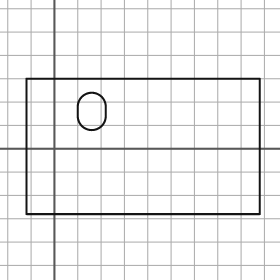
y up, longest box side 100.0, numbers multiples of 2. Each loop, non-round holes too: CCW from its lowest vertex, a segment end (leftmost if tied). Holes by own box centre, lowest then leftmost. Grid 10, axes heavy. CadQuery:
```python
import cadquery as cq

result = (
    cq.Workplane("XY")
    .moveTo(-12.0, -28.0)
    .lineTo(88.0, -28.0)
    .lineTo(88.0, 30.0)
    .lineTo(-12.0, 30.0)
    .close()
    .moveTo(10.0, 14.0)
    .threePointArc((16.0, 8.0), (22.0, 14.0))
    .lineTo(22.0, 18.0)
    .threePointArc((16.0, 24.0), (10.0, 18.0))
    .close()
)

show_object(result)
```